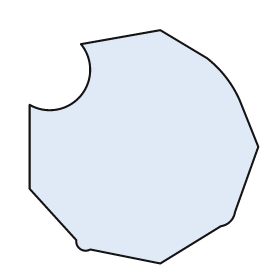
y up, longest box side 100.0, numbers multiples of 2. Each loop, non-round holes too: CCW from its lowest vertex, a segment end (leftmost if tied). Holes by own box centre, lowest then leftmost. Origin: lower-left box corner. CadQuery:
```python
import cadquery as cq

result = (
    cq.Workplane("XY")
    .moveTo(56.0, 0.0)
    .lineTo(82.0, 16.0)
    .threePointArc((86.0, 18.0), (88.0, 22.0))
    .lineTo(98.0, 50.0)
    .lineTo(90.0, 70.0)
    .threePointArc((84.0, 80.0), (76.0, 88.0))
    .lineTo(56.0, 100.0)
    .lineTo(22.0, 94.0)
    .threePointArc((22.0, 72.0), (0.0, 68.0))
    .lineTo(0.0, 32.0)
    .lineTo(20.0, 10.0)
    .threePointArc((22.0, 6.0), (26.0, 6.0))
    .close()
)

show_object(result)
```